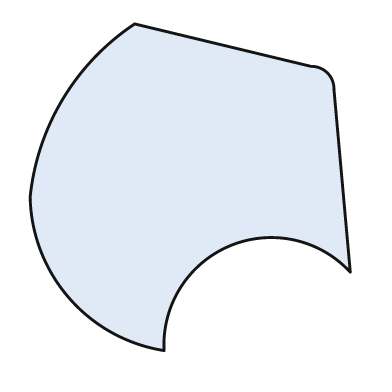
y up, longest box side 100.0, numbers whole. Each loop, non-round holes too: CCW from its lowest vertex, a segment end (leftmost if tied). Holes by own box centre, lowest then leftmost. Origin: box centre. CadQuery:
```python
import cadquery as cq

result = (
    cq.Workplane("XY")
    .moveTo(-8.0, -50.0)
    .threePointArc((12.0, -18.0), (49.0, -26.0))
    .lineTo(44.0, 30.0)
    .threePointArc((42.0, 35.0), (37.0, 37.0))
    .lineTo(-17.0, 50.0)
    .threePointArc((-39.0, 27.0), (-49.0, -3.0))
    .threePointArc((-37.0, -34.0), (-8.0, -50.0))
    .close()
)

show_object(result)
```